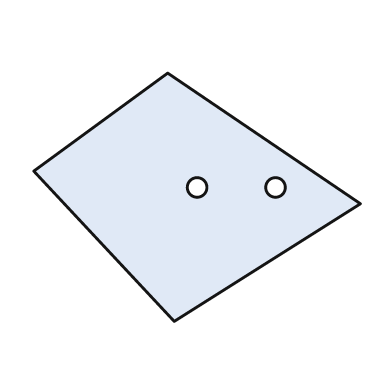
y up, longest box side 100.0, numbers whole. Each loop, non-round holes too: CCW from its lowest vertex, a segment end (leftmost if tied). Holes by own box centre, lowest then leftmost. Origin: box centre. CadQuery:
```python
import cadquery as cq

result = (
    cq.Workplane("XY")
    .moveTo(-7.0, -38.0)
    .lineTo(50.0, -2.0)
    .lineTo(-9.0, 38.0)
    .lineTo(-50.0, 8.0)
    .close()
    .moveTo(0.0, 3.0)
    .circle(3.0)
    .moveTo(24.0, 3.0)
    .circle(3.0)
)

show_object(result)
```